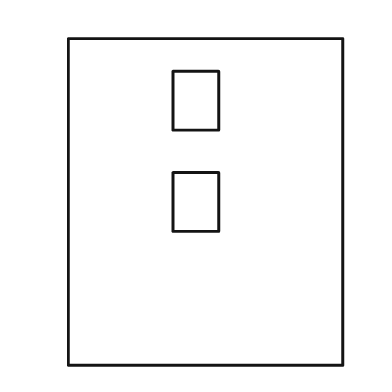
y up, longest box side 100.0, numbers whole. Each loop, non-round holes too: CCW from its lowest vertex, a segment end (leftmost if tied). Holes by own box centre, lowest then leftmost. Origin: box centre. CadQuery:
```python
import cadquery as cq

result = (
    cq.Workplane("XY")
    .moveTo(-42.0, -50.0)
    .lineTo(42.0, -50.0)
    .lineTo(42.0, 50.0)
    .lineTo(-42.0, 50.0)
    .close()
    .moveTo(-10.0, -9.0)
    .lineTo(4.0, -9.0)
    .lineTo(4.0, 9.0)
    .lineTo(-10.0, 9.0)
    .close()
    .moveTo(-10.0, 22.0)
    .lineTo(4.0, 22.0)
    .lineTo(4.0, 40.0)
    .lineTo(-10.0, 40.0)
    .close()
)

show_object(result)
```